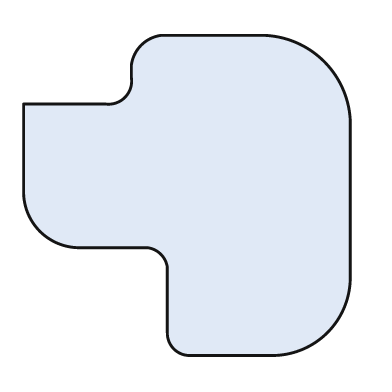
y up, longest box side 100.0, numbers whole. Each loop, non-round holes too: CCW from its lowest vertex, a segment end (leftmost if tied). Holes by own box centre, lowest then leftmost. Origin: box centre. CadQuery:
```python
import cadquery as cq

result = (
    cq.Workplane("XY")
    .moveTo(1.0, -49.0)
    .lineTo(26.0, -49.0)
    .threePointArc((43.0, -42.0), (50.0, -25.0))
    .lineTo(50.0, 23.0)
    .threePointArc((42.0, 41.0), (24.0, 49.0))
    .lineTo(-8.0, 49.0)
    .threePointArc((-14.0, 46.0), (-17.0, 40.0))
    .lineTo(-17.0, 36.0)
    .threePointArc((-19.0, 30.0), (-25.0, 28.0))
    .lineTo(-50.0, 28.0)
    .lineTo(-50.0, 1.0)
    .threePointArc((-45.0, -11.0), (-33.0, -16.0))
    .lineTo(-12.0, -16.0)
    .threePointArc((-8.0, -18.0), (-6.0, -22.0))
    .lineTo(-6.0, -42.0)
    .threePointArc((-4.0, -47.0), (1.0, -49.0))
    .close()
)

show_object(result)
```